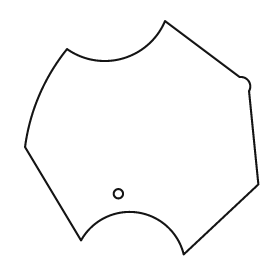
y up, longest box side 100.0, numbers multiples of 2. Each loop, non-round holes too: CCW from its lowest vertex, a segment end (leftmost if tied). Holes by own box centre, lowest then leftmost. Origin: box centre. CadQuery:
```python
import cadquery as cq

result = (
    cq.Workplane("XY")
    .moveTo(18.0, -50.0)
    .lineTo(50.0, -20.0)
    .lineTo(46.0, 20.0)
    .threePointArc((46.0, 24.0), (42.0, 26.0))
    .lineTo(10.0, 50.0)
    .threePointArc((-8.0, 34.0), (-32.0, 38.0))
    .threePointArc((-44.0, 18.0), (-50.0, -4.0))
    .lineTo(-26.0, -44.0)
    .threePointArc((-2.0, -32.0), (18.0, -50.0))
    .close()
    .moveTo(-10.0, -24.0)
    .circle(2.0)
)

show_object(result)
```